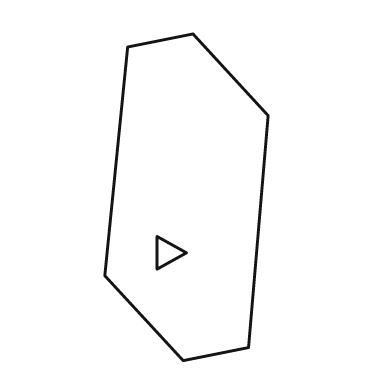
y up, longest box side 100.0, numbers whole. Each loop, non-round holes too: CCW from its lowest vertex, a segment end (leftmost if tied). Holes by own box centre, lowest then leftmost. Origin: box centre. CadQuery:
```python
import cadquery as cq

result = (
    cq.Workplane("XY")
    .moveTo(-1.0, -50.0)
    .lineTo(19.0, -46.0)
    .lineTo(25.0, 25.0)
    .lineTo(2.0, 50.0)
    .lineTo(-18.0, 46.0)
    .lineTo(-25.0, -24.0)
    .close()
    .moveTo(-9.0, -22.0)
    .lineTo(0.0, -17.0)
    .lineTo(-9.0, -12.0)
    .close()
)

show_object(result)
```